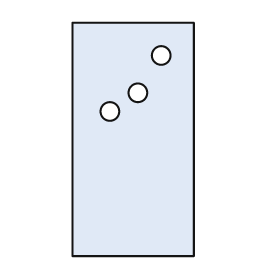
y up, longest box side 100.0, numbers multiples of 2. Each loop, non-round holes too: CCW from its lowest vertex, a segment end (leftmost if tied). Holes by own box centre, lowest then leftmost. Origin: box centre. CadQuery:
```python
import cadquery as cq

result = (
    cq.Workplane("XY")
    .moveTo(-26.0, -50.0)
    .lineTo(26.0, -50.0)
    .lineTo(26.0, 50.0)
    .lineTo(-26.0, 50.0)
    .close()
    .moveTo(-10.0, 12.0)
    .circle(4.0)
    .moveTo(2.0, 20.0)
    .circle(4.0)
    .moveTo(12.0, 36.0)
    .circle(4.0)
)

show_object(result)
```